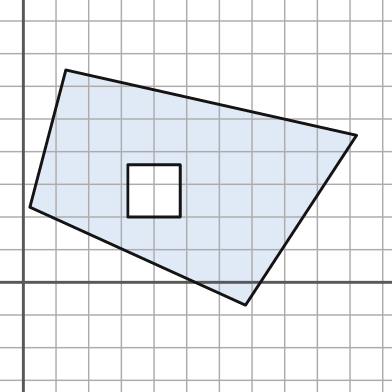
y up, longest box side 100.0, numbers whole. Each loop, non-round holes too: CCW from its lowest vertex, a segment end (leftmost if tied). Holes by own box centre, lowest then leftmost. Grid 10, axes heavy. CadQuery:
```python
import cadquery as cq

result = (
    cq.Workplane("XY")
    .moveTo(68.0, -7.0)
    .lineTo(102.0, 45.0)
    .lineTo(13.0, 65.0)
    .lineTo(2.0, 23.0)
    .close()
    .moveTo(32.0, 20.0)
    .lineTo(48.0, 20.0)
    .lineTo(48.0, 36.0)
    .lineTo(32.0, 36.0)
    .close()
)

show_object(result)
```